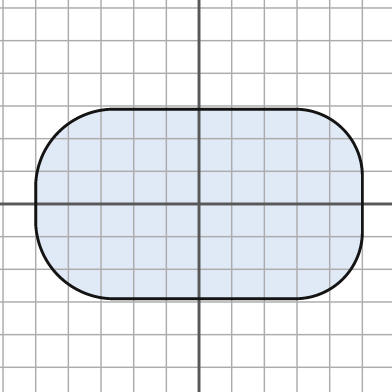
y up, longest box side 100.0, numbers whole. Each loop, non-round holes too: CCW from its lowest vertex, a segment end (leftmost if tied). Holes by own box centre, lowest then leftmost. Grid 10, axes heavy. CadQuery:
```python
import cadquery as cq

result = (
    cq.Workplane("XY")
    .moveTo(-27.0, -29.0)
    .lineTo(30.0, -29.0)
    .threePointArc((44.0, -23.0), (50.0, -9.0))
    .lineTo(50.0, 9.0)
    .threePointArc((44.0, 23.0), (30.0, 29.0))
    .lineTo(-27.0, 29.0)
    .threePointArc((-43.0, 22.0), (-50.0, 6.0))
    .lineTo(-50.0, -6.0)
    .threePointArc((-43.0, -22.0), (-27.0, -29.0))
    .close()
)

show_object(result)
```